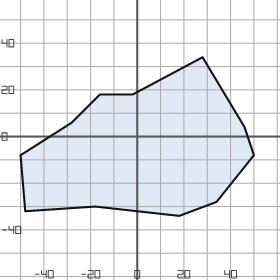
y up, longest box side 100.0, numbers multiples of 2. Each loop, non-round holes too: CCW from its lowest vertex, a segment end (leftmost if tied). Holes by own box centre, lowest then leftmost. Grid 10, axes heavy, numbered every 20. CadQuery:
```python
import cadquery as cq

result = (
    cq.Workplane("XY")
    .moveTo(18.0, -34.0)
    .lineTo(34.0, -28.0)
    .lineTo(50.0, -8.0)
    .lineTo(46.0, 4.0)
    .lineTo(28.0, 34.0)
    .lineTo(-2.0, 18.0)
    .lineTo(-16.0, 18.0)
    .lineTo(-28.0, 6.0)
    .lineTo(-50.0, -8.0)
    .lineTo(-48.0, -32.0)
    .lineTo(-18.0, -30.0)
    .close()
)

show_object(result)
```